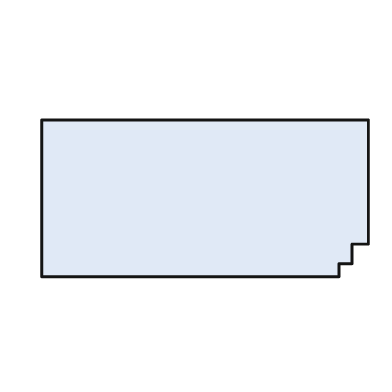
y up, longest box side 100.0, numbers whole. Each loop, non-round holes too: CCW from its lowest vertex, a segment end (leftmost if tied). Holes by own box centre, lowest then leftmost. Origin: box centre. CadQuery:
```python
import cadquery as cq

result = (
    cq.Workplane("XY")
    .moveTo(-50.0, -24.0)
    .lineTo(41.0, -24.0)
    .lineTo(41.0, -20.0)
    .lineTo(45.0, -20.0)
    .lineTo(45.0, -14.0)
    .lineTo(50.0, -14.0)
    .lineTo(50.0, 24.0)
    .lineTo(-50.0, 24.0)
    .close()
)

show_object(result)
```